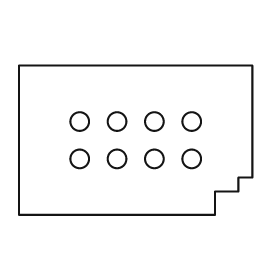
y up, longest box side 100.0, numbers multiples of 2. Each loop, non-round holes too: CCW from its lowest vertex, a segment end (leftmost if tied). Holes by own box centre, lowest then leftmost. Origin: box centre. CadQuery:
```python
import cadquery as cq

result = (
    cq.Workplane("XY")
    .moveTo(-50.0, -32.0)
    .lineTo(34.0, -32.0)
    .lineTo(34.0, -22.0)
    .lineTo(44.0, -22.0)
    .lineTo(44.0, -16.0)
    .lineTo(50.0, -16.0)
    .lineTo(50.0, 32.0)
    .lineTo(-50.0, 32.0)
    .close()
    .moveTo(-24.0, -8.0)
    .circle(4.0)
    .moveTo(-8.0, -8.0)
    .circle(4.0)
    .moveTo(8.0, -8.0)
    .circle(4.0)
    .moveTo(24.0, -8.0)
    .circle(4.0)
    .moveTo(-24.0, 8.0)
    .circle(4.0)
    .moveTo(-8.0, 8.0)
    .circle(4.0)
    .moveTo(8.0, 8.0)
    .circle(4.0)
    .moveTo(24.0, 8.0)
    .circle(4.0)
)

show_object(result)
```